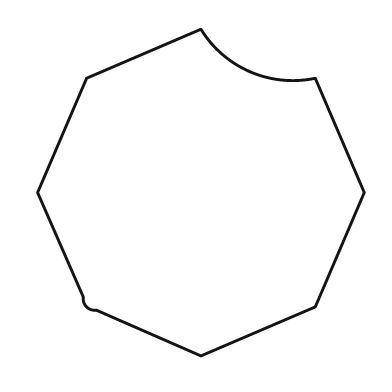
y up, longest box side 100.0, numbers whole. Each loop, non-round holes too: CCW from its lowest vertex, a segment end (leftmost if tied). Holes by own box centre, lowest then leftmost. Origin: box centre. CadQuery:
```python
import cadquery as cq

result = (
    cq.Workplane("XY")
    .moveTo(0.0, -50.0)
    .lineTo(35.0, -35.0)
    .lineTo(50.0, 0.0)
    .lineTo(35.0, 35.0)
    .threePointArc((15.0, 37.0), (0.0, 50.0))
    .lineTo(-35.0, 35.0)
    .lineTo(-50.0, 0.0)
    .lineTo(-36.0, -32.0)
    .threePointArc((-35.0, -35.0), (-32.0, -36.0))
    .close()
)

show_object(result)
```